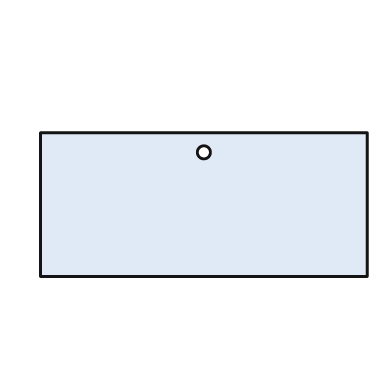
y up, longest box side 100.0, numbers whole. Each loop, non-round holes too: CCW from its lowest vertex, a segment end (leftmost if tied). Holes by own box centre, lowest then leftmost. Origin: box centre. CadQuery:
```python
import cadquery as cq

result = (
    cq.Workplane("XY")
    .moveTo(-50.0, -22.0)
    .lineTo(50.0, -22.0)
    .lineTo(50.0, 22.0)
    .lineTo(-50.0, 22.0)
    .close()
    .moveTo(0.0, 16.0)
    .circle(2.0)
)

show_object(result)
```